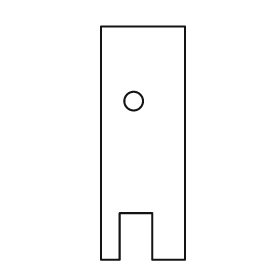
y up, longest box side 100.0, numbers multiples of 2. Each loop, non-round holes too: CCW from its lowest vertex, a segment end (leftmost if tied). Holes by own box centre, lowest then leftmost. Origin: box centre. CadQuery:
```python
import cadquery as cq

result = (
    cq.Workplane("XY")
    .moveTo(-18.0, -50.0)
    .lineTo(-10.0, -50.0)
    .lineTo(-10.0, -30.0)
    .lineTo(4.0, -30.0)
    .lineTo(4.0, -50.0)
    .lineTo(18.0, -50.0)
    .lineTo(18.0, 50.0)
    .lineTo(-18.0, 50.0)
    .close()
    .moveTo(-4.0, 18.0)
    .circle(4.0)
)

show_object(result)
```